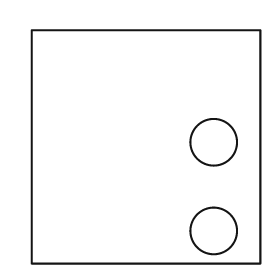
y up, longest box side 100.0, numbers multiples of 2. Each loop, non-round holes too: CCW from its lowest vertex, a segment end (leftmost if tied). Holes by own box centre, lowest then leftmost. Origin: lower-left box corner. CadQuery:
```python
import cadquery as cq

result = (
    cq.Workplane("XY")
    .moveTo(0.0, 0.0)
    .lineTo(98.0, 0.0)
    .lineTo(98.0, 100.0)
    .lineTo(0.0, 100.0)
    .close()
    .moveTo(78.0, 14.0)
    .circle(10.0)
    .moveTo(78.0, 52.0)
    .circle(10.0)
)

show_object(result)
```